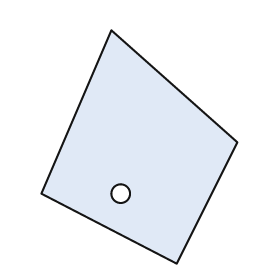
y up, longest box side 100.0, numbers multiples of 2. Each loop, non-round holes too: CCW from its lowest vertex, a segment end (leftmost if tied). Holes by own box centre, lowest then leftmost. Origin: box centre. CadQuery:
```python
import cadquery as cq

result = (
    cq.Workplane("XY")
    .moveTo(16.0, -50.0)
    .lineTo(42.0, 2.0)
    .lineTo(-12.0, 50.0)
    .lineTo(-42.0, -20.0)
    .close()
    .moveTo(-8.0, -20.0)
    .circle(4.0)
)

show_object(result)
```